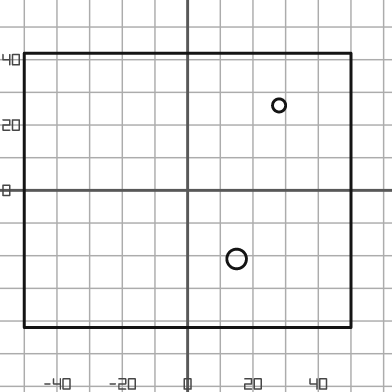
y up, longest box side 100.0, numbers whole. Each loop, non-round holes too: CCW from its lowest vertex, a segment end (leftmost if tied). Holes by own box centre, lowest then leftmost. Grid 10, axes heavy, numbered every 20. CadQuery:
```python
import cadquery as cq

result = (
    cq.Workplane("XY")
    .moveTo(-50.0, -42.0)
    .lineTo(50.0, -42.0)
    .lineTo(50.0, 42.0)
    .lineTo(-50.0, 42.0)
    .close()
    .moveTo(15.0, -21.0)
    .circle(3.0)
    .moveTo(28.0, 26.0)
    .circle(2.0)
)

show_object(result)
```